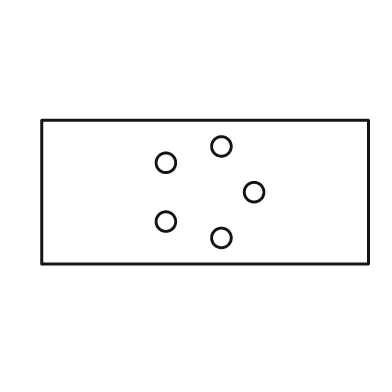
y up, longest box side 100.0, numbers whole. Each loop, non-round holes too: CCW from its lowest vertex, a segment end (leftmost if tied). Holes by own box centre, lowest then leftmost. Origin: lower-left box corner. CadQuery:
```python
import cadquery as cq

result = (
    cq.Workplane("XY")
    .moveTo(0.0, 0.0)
    .lineTo(100.0, 0.0)
    .lineTo(100.0, 44.0)
    .lineTo(0.0, 44.0)
    .close()
    .moveTo(55.0, 8.0)
    .circle(3.0)
    .moveTo(38.0, 13.0)
    .circle(3.0)
    .moveTo(65.0, 22.0)
    .circle(3.0)
    .moveTo(38.0, 31.0)
    .circle(3.0)
    .moveTo(55.0, 36.0)
    .circle(3.0)
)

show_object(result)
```